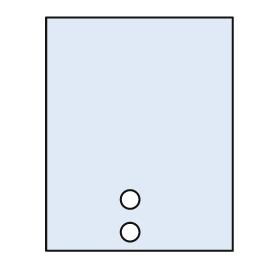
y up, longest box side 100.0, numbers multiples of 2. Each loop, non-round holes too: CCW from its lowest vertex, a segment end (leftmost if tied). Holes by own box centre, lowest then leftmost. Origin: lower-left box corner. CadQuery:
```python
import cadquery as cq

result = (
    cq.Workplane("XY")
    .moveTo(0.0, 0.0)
    .lineTo(80.0, 0.0)
    .lineTo(80.0, 100.0)
    .lineTo(0.0, 100.0)
    .close()
    .moveTo(36.0, 8.0)
    .circle(4.0)
    .moveTo(36.0, 22.0)
    .circle(4.0)
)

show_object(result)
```